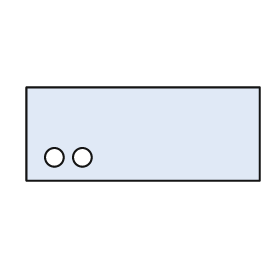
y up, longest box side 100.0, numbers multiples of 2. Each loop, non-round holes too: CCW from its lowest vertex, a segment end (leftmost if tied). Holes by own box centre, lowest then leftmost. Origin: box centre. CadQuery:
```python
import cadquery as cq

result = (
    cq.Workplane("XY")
    .moveTo(-50.0, -20.0)
    .lineTo(50.0, -20.0)
    .lineTo(50.0, 20.0)
    .lineTo(-50.0, 20.0)
    .close()
    .moveTo(-38.0, -10.0)
    .circle(4.0)
    .moveTo(-26.0, -10.0)
    .circle(4.0)
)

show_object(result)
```